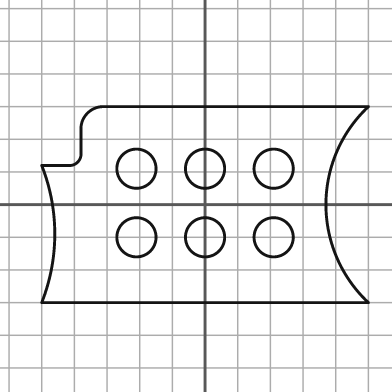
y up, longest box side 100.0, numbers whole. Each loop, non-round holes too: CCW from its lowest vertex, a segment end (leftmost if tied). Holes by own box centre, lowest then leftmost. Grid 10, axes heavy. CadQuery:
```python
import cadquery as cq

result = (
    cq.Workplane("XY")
    .moveTo(-50.0, -30.0)
    .lineTo(50.0, -30.0)
    .threePointArc((37.0, 0.0), (50.0, 30.0))
    .lineTo(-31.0, 30.0)
    .threePointArc((-36.0, 28.0), (-38.0, 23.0))
    .lineTo(-38.0, 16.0)
    .threePointArc((-39.0, 13.0), (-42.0, 12.0))
    .lineTo(-50.0, 12.0)
    .threePointArc((-46.0, -9.0), (-50.0, -30.0))
    .close()
    .moveTo(-21.0, -10.0)
    .circle(6.0)
    .moveTo(0.0, -10.0)
    .circle(6.0)
    .moveTo(21.0, -10.0)
    .circle(6.0)
    .moveTo(-21.0, 11.0)
    .circle(6.0)
    .moveTo(0.0, 11.0)
    .circle(6.0)
    .moveTo(21.0, 11.0)
    .circle(6.0)
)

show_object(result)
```